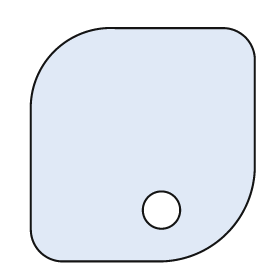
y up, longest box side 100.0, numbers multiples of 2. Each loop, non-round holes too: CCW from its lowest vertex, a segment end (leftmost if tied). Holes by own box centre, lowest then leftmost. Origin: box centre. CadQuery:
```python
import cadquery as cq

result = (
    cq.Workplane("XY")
    .moveTo(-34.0, -50.0)
    .lineTo(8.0, -50.0)
    .threePointArc((36.0, -38.0), (48.0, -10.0))
    .lineTo(48.0, 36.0)
    .threePointArc((44.0, 46.0), (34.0, 50.0))
    .lineTo(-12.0, 50.0)
    .threePointArc((-38.0, 40.0), (-48.0, 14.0))
    .lineTo(-48.0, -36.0)
    .threePointArc((-44.0, -46.0), (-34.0, -50.0))
    .close()
    .moveTo(8.0, -28.0)
    .circle(8.0)
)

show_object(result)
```